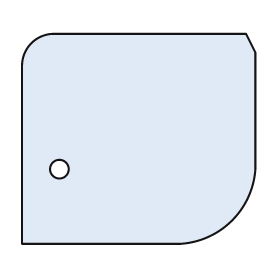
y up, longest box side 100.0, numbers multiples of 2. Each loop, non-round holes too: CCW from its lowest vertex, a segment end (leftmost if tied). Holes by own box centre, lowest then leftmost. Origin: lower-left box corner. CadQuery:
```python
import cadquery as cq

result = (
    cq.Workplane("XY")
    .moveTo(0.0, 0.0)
    .lineTo(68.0, 0.0)
    .threePointArc((90.0, 10.0), (100.0, 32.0))
    .lineTo(100.0, 82.0)
    .lineTo(96.0, 90.0)
    .lineTo(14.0, 90.0)
    .threePointArc((4.0, 86.0), (0.0, 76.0))
    .close()
    .moveTo(16.0, 32.0)
    .circle(4.0)
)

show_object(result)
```